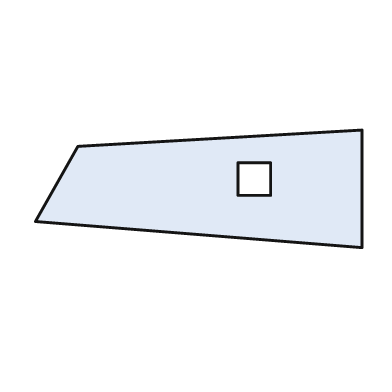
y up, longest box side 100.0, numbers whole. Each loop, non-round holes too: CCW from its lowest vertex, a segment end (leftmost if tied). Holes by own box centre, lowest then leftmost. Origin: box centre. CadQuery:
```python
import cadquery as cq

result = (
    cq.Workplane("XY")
    .moveTo(50.0, -18.0)
    .lineTo(50.0, 18.0)
    .lineTo(-37.0, 13.0)
    .lineTo(-50.0, -10.0)
    .close()
    .moveTo(12.0, -2.0)
    .lineTo(22.0, -2.0)
    .lineTo(22.0, 8.0)
    .lineTo(12.0, 8.0)
    .close()
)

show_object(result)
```